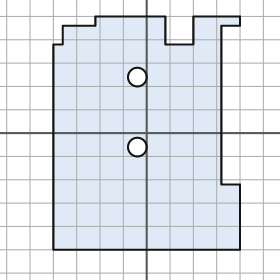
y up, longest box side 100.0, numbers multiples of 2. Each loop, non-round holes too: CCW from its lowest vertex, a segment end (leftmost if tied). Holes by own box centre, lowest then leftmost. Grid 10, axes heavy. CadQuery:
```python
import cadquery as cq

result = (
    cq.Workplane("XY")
    .moveTo(-40.0, -50.0)
    .lineTo(40.0, -50.0)
    .lineTo(40.0, -22.0)
    .lineTo(32.0, -22.0)
    .lineTo(32.0, 46.0)
    .lineTo(40.0, 46.0)
    .lineTo(40.0, 50.0)
    .lineTo(20.0, 50.0)
    .lineTo(20.0, 38.0)
    .lineTo(8.0, 38.0)
    .lineTo(8.0, 50.0)
    .lineTo(-22.0, 50.0)
    .lineTo(-22.0, 46.0)
    .lineTo(-36.0, 46.0)
    .lineTo(-36.0, 38.0)
    .lineTo(-40.0, 38.0)
    .close()
    .moveTo(-4.0, -6.0)
    .circle(4.0)
    .moveTo(-4.0, 24.0)
    .circle(4.0)
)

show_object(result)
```